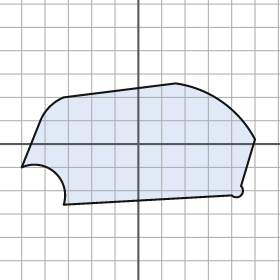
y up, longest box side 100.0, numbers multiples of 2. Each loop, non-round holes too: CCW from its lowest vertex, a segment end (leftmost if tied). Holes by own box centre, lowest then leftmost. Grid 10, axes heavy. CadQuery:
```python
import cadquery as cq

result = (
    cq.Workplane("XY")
    .moveTo(-32.0, -26.0)
    .lineTo(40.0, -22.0)
    .threePointArc((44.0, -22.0), (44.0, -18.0))
    .lineTo(50.0, 2.0)
    .threePointArc((36.0, 18.0), (16.0, 26.0))
    .lineTo(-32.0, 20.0)
    .threePointArc((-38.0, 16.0), (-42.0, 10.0))
    .lineTo(-50.0, -10.0)
    .threePointArc((-36.0, -12.0), (-32.0, -26.0))
    .close()
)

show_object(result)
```